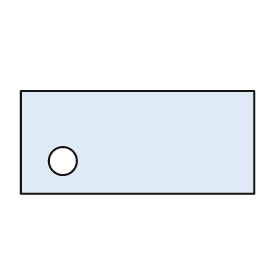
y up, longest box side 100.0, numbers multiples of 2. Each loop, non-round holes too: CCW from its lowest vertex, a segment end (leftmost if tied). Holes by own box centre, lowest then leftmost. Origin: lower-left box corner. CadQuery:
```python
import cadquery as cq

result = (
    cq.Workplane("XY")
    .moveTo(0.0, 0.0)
    .lineTo(100.0, 0.0)
    .lineTo(100.0, 44.0)
    .lineTo(0.0, 44.0)
    .close()
    .moveTo(18.0, 14.0)
    .circle(6.0)
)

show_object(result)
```